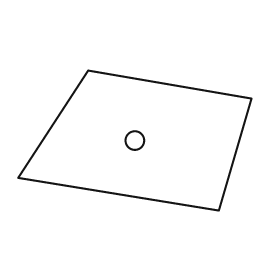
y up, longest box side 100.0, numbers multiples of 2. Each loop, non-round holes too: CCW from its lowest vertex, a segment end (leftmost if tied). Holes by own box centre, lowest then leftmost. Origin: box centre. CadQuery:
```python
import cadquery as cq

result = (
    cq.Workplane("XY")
    .moveTo(36.0, -30.0)
    .lineTo(50.0, 18.0)
    .lineTo(-20.0, 30.0)
    .lineTo(-50.0, -16.0)
    .close()
    .moveTo(0.0, 0.0)
    .circle(4.0)
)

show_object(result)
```